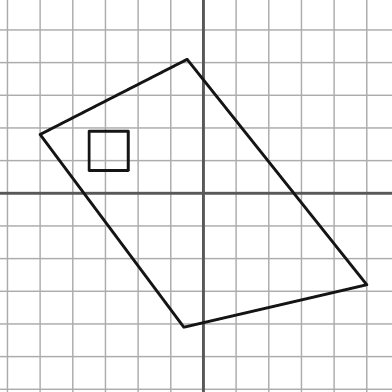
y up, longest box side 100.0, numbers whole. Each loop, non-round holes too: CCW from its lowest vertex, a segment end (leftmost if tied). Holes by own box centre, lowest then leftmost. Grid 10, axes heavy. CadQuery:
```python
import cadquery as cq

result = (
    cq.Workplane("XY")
    .moveTo(-6.0, -41.0)
    .lineTo(50.0, -28.0)
    .lineTo(-5.0, 41.0)
    .lineTo(-50.0, 18.0)
    .close()
    .moveTo(-35.0, 7.0)
    .lineTo(-23.0, 7.0)
    .lineTo(-23.0, 19.0)
    .lineTo(-35.0, 19.0)
    .close()
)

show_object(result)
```